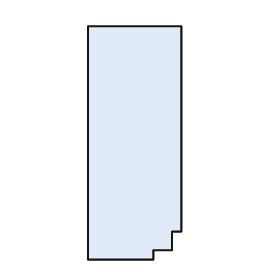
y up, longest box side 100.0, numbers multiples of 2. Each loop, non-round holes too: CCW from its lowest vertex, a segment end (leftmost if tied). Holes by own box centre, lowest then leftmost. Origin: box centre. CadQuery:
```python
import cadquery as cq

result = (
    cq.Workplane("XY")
    .moveTo(-20.0, -50.0)
    .lineTo(8.0, -50.0)
    .lineTo(8.0, -46.0)
    .lineTo(16.0, -46.0)
    .lineTo(16.0, -38.0)
    .lineTo(20.0, -38.0)
    .lineTo(20.0, 50.0)
    .lineTo(-20.0, 50.0)
    .close()
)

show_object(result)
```